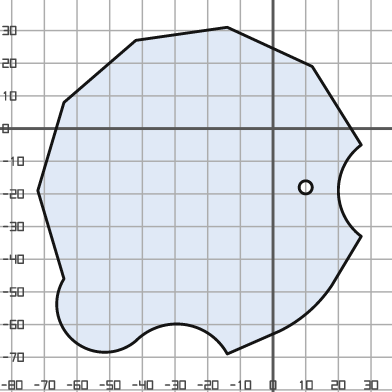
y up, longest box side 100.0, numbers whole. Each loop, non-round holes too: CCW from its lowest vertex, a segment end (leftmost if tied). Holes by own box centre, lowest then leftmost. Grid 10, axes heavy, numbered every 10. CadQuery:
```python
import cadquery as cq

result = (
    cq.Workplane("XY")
    .moveTo(-14.0, -69.0)
    .lineTo(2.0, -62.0)
    .threePointArc((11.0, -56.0), (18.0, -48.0))
    .lineTo(27.0, -33.0)
    .threePointArc((20.0, -19.0), (27.0, -5.0))
    .lineTo(12.0, 19.0)
    .lineTo(-14.0, 31.0)
    .lineTo(-42.0, 27.0)
    .lineTo(-64.0, 8.0)
    .lineTo(-72.0, -19.0)
    .lineTo(-64.0, -46.0)
    .threePointArc((-61.0, -65.0), (-42.0, -65.0))
    .threePointArc((-27.0, -60.0), (-14.0, -69.0))
    .close()
    .moveTo(10.0, -18.0)
    .circle(2.0)
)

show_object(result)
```